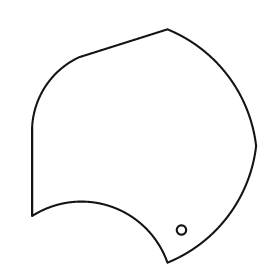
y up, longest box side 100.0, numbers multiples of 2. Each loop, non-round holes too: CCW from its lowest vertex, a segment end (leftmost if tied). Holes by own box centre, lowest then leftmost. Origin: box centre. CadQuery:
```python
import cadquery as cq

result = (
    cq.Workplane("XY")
    .moveTo(10.0, -50.0)
    .threePointArc((36.0, -30.0), (48.0, 0.0))
    .threePointArc((36.0, 30.0), (10.0, 50.0))
    .lineTo(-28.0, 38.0)
    .threePointArc((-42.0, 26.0), (-48.0, 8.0))
    .lineTo(-48.0, -30.0)
    .threePointArc((-14.0, -26.0), (10.0, -50.0))
    .close()
    .moveTo(16.0, -36.0)
    .circle(2.0)
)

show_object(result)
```